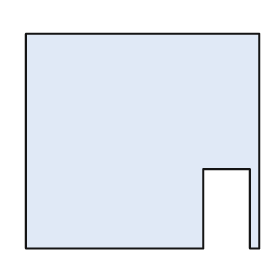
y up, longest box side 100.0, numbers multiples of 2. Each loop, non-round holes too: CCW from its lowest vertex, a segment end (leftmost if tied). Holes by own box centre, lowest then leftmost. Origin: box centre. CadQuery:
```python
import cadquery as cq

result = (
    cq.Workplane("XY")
    .moveTo(-50.0, -46.0)
    .lineTo(26.0, -46.0)
    .lineTo(26.0, -12.0)
    .lineTo(46.0, -12.0)
    .lineTo(46.0, -46.0)
    .lineTo(50.0, -46.0)
    .lineTo(50.0, 46.0)
    .lineTo(-50.0, 46.0)
    .close()
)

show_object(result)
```